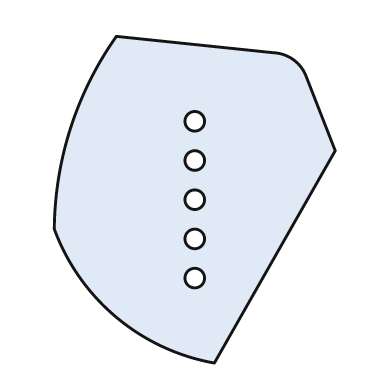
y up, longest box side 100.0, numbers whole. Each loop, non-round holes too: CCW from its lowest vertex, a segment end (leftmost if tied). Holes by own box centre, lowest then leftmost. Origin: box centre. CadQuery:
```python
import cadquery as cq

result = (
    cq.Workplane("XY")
    .moveTo(6.0, -50.0)
    .lineTo(43.0, 15.0)
    .lineTo(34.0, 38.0)
    .threePointArc((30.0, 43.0), (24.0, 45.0))
    .lineTo(-24.0, 50.0)
    .threePointArc((-38.0, 22.0), (-43.0, -9.0))
    .threePointArc((-24.0, -36.0), (6.0, -50.0))
    .close()
    .moveTo(0.0, -24.0)
    .circle(3.0)
    .moveTo(0.0, -12.0)
    .circle(3.0)
    .moveTo(0.0, 0.0)
    .circle(3.0)
    .moveTo(0.0, 12.0)
    .circle(3.0)
    .moveTo(0.0, 24.0)
    .circle(3.0)
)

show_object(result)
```